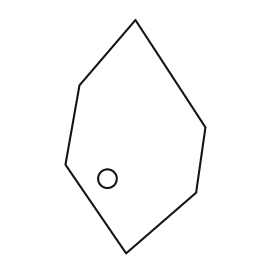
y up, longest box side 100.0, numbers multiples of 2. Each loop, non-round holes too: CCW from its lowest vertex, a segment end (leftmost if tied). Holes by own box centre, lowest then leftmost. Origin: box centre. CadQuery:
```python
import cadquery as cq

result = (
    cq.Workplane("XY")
    .moveTo(-4.0, -50.0)
    .lineTo(26.0, -24.0)
    .lineTo(30.0, 4.0)
    .lineTo(0.0, 50.0)
    .lineTo(-24.0, 22.0)
    .lineTo(-30.0, -12.0)
    .close()
    .moveTo(-12.0, -18.0)
    .circle(4.0)
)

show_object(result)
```